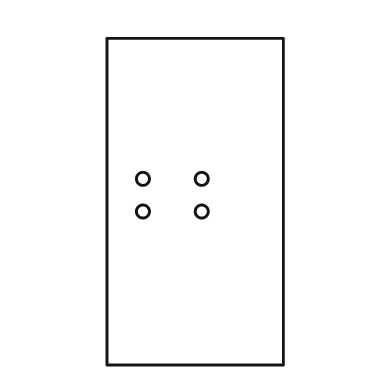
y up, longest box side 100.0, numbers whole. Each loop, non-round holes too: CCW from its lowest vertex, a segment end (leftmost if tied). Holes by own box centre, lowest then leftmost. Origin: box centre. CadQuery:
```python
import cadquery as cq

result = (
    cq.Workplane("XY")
    .moveTo(-27.0, -50.0)
    .lineTo(27.0, -50.0)
    .lineTo(27.0, 50.0)
    .lineTo(-27.0, 50.0)
    .close()
    .moveTo(-16.0, -3.0)
    .circle(2.0)
    .moveTo(2.0, -3.0)
    .circle(2.0)
    .moveTo(-16.0, 7.0)
    .circle(2.0)
    .moveTo(2.0, 7.0)
    .circle(2.0)
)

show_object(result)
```